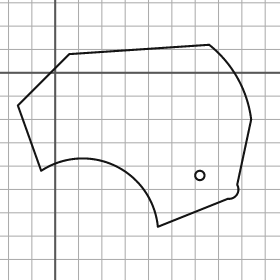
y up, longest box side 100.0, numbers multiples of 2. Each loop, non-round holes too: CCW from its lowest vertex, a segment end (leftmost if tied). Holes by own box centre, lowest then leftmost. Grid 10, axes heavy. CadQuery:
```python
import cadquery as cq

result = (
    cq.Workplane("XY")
    .moveTo(44.0, -66.0)
    .lineTo(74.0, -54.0)
    .threePointArc((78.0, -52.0), (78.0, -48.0))
    .lineTo(84.0, -20.0)
    .threePointArc((78.0, -2.0), (66.0, 12.0))
    .lineTo(6.0, 8.0)
    .lineTo(-16.0, -14.0)
    .lineTo(-6.0, -42.0)
    .threePointArc((26.0, -40.0), (44.0, -66.0))
    .close()
    .moveTo(62.0, -44.0)
    .circle(2.0)
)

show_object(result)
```